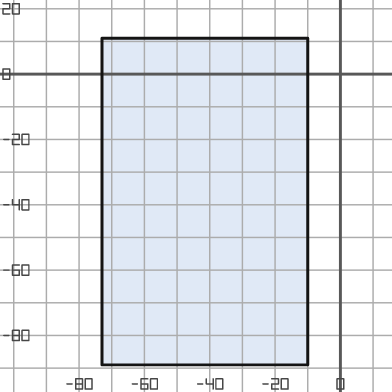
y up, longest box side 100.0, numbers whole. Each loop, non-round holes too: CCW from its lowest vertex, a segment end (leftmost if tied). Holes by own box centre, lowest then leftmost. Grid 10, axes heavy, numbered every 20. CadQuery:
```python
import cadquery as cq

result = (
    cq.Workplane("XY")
    .moveTo(-73.0, -89.0)
    .lineTo(-10.0, -89.0)
    .lineTo(-10.0, 11.0)
    .lineTo(-73.0, 11.0)
    .close()
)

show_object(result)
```